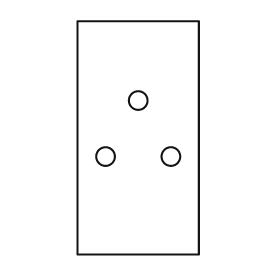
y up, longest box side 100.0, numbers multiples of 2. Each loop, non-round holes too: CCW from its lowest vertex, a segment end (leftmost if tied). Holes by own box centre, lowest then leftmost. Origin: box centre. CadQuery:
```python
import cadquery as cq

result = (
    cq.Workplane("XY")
    .moveTo(-26.0, -50.0)
    .lineTo(26.0, -50.0)
    .lineTo(26.0, 50.0)
    .lineTo(-26.0, 50.0)
    .close()
    .moveTo(-14.0, -8.0)
    .circle(4.0)
    .moveTo(14.0, -8.0)
    .circle(4.0)
    .moveTo(0.0, 16.0)
    .circle(4.0)
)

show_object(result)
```